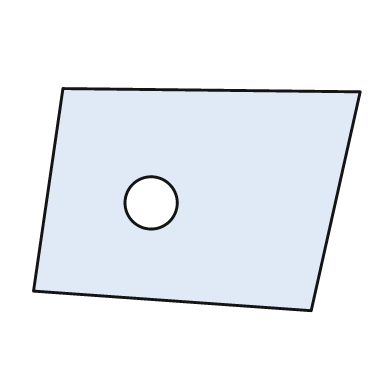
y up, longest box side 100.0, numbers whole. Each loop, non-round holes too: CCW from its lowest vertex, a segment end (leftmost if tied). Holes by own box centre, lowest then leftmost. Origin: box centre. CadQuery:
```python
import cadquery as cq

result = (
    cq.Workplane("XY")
    .moveTo(35.0, -34.0)
    .lineTo(50.0, 33.0)
    .lineTo(-41.0, 34.0)
    .lineTo(-50.0, -28.0)
    .close()
    .moveTo(-14.0, -1.0)
    .circle(8.0)
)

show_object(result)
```